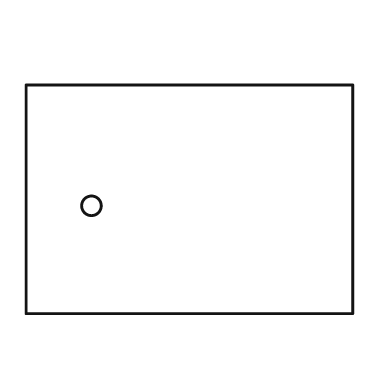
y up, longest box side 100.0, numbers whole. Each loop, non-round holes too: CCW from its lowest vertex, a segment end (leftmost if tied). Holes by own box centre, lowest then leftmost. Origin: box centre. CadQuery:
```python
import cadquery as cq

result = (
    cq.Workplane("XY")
    .moveTo(-50.0, -35.0)
    .lineTo(50.0, -35.0)
    .lineTo(50.0, 35.0)
    .lineTo(-50.0, 35.0)
    .close()
    .moveTo(-30.0, -2.0)
    .circle(3.0)
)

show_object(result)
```